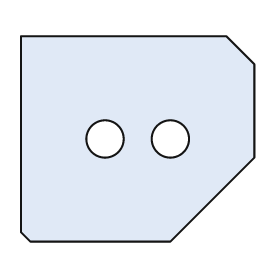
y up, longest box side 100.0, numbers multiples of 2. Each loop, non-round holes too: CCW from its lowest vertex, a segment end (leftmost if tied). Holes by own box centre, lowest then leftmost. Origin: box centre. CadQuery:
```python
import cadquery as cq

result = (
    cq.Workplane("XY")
    .moveTo(-46.0, -44.0)
    .lineTo(14.0, -44.0)
    .lineTo(50.0, -8.0)
    .lineTo(50.0, 32.0)
    .lineTo(38.0, 44.0)
    .lineTo(-50.0, 44.0)
    .lineTo(-50.0, -40.0)
    .close()
    .moveTo(-14.0, 0.0)
    .circle(8.0)
    .moveTo(14.0, 0.0)
    .circle(8.0)
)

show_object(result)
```